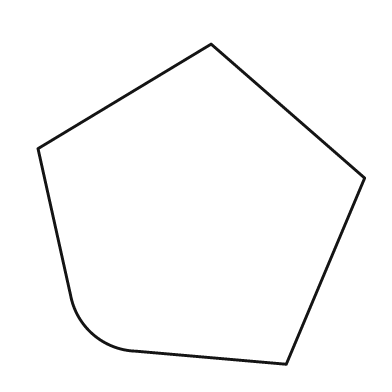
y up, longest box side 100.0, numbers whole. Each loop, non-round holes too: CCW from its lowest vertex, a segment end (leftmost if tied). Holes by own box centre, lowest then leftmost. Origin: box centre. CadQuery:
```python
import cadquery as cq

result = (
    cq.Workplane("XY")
    .moveTo(26.0, -49.0)
    .lineTo(50.0, 8.0)
    .lineTo(3.0, 49.0)
    .lineTo(-50.0, 17.0)
    .lineTo(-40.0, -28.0)
    .threePointArc((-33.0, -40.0), (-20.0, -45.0))
    .close()
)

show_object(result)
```